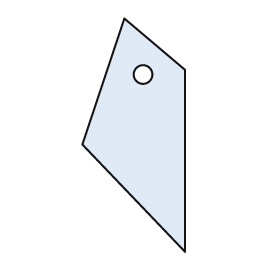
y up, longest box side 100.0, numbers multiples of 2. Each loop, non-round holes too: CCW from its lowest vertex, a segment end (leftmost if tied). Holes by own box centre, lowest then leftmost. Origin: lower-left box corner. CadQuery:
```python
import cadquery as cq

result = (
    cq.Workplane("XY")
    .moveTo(44.0, 0.0)
    .lineTo(44.0, 78.0)
    .lineTo(18.0, 100.0)
    .lineTo(0.0, 46.0)
    .close()
    .moveTo(26.0, 76.0)
    .circle(4.0)
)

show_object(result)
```